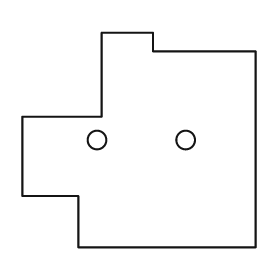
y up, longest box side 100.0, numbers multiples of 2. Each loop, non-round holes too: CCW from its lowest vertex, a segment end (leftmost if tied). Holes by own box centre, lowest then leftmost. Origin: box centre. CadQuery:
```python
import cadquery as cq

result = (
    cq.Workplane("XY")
    .moveTo(-26.0, -46.0)
    .lineTo(50.0, -46.0)
    .lineTo(50.0, 38.0)
    .lineTo(6.0, 38.0)
    .lineTo(6.0, 46.0)
    .lineTo(-16.0, 46.0)
    .lineTo(-16.0, 10.0)
    .lineTo(-50.0, 10.0)
    .lineTo(-50.0, -24.0)
    .lineTo(-26.0, -24.0)
    .close()
    .moveTo(-18.0, 0.0)
    .circle(4.0)
    .moveTo(20.0, 0.0)
    .circle(4.0)
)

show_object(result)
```